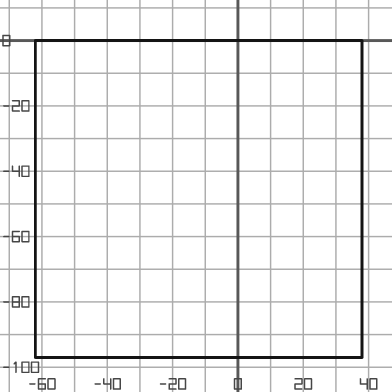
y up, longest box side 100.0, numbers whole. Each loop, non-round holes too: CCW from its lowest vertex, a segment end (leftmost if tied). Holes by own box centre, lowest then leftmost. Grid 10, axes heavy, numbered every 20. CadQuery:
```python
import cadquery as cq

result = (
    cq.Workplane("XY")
    .moveTo(-62.0, -97.0)
    .lineTo(38.0, -97.0)
    .lineTo(38.0, 0.0)
    .lineTo(-62.0, 0.0)
    .close()
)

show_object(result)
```